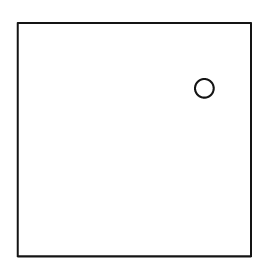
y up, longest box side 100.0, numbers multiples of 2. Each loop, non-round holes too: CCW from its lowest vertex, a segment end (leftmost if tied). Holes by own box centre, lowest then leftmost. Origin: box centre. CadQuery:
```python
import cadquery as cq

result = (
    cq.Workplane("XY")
    .moveTo(-50.0, -50.0)
    .lineTo(50.0, -50.0)
    .lineTo(50.0, 50.0)
    .lineTo(-50.0, 50.0)
    .close()
    .moveTo(30.0, 22.0)
    .circle(4.0)
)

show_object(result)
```